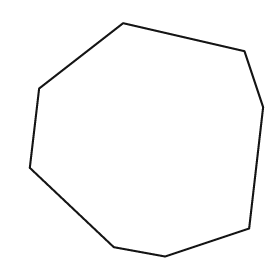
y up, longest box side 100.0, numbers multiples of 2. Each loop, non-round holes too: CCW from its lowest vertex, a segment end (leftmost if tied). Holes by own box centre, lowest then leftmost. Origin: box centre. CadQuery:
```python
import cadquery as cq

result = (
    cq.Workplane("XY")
    .moveTo(8.0, -50.0)
    .lineTo(44.0, -38.0)
    .lineTo(50.0, 14.0)
    .lineTo(42.0, 38.0)
    .lineTo(-10.0, 50.0)
    .lineTo(-46.0, 22.0)
    .lineTo(-50.0, -12.0)
    .lineTo(-14.0, -46.0)
    .close()
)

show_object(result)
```